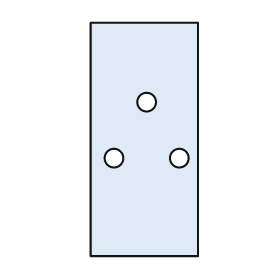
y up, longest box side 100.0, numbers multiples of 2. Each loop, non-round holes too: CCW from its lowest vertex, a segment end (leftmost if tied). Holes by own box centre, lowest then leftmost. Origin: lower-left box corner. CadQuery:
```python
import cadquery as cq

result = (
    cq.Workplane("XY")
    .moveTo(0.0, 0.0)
    .lineTo(46.0, 0.0)
    .lineTo(46.0, 100.0)
    .lineTo(0.0, 100.0)
    .close()
    .moveTo(10.0, 42.0)
    .circle(4.0)
    .moveTo(38.0, 42.0)
    .circle(4.0)
    .moveTo(24.0, 66.0)
    .circle(4.0)
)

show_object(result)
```